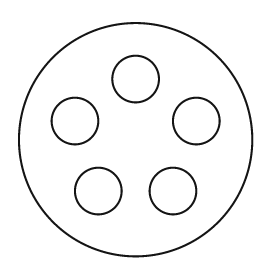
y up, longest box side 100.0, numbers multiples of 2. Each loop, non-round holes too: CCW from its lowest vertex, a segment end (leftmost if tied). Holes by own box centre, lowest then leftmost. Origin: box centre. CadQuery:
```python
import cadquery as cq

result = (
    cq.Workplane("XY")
    .moveTo(0.0, 0.0)
    .circle(50.0)
    .moveTo(-16.0, -22.0)
    .circle(10.0)
    .moveTo(16.0, -22.0)
    .circle(10.0)
    .moveTo(-26.0, 8.0)
    .circle(10.0)
    .moveTo(26.0, 8.0)
    .circle(10.0)
    .moveTo(0.0, 26.0)
    .circle(10.0)
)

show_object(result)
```